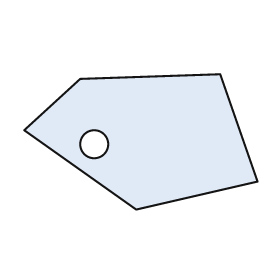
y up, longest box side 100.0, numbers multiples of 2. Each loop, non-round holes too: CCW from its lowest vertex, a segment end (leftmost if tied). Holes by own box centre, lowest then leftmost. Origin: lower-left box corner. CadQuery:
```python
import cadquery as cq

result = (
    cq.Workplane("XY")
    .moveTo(48.0, 0.0)
    .lineTo(100.0, 12.0)
    .lineTo(84.0, 58.0)
    .lineTo(24.0, 56.0)
    .lineTo(0.0, 34.0)
    .close()
    .moveTo(30.0, 28.0)
    .circle(6.0)
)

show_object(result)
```